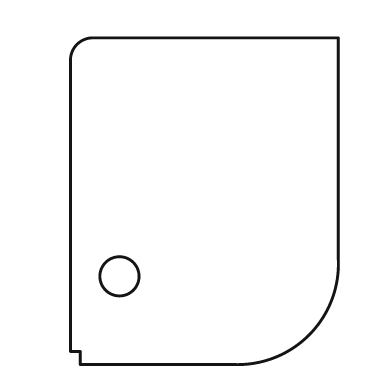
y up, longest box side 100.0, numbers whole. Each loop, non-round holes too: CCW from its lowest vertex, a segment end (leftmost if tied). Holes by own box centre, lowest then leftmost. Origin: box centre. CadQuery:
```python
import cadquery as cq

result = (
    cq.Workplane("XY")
    .moveTo(-38.0, -50.0)
    .lineTo(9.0, -50.0)
    .threePointArc((32.0, -41.0), (41.0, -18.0))
    .lineTo(41.0, 50.0)
    .lineTo(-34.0, 50.0)
    .threePointArc((-39.0, 48.0), (-41.0, 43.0))
    .lineTo(-41.0, -46.0)
    .lineTo(-38.0, -46.0)
    .close()
    .moveTo(-26.0, -23.0)
    .circle(6.0)
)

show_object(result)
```